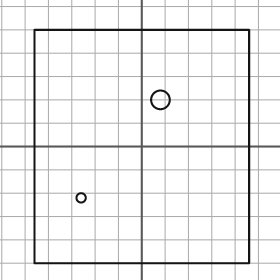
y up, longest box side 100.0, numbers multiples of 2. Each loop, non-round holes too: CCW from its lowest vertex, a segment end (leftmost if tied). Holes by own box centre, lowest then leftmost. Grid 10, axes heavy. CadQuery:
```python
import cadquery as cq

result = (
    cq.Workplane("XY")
    .moveTo(-46.0, -50.0)
    .lineTo(46.0, -50.0)
    .lineTo(46.0, 50.0)
    .lineTo(-46.0, 50.0)
    .close()
    .moveTo(-26.0, -22.0)
    .circle(2.0)
    .moveTo(8.0, 20.0)
    .circle(4.0)
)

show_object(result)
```